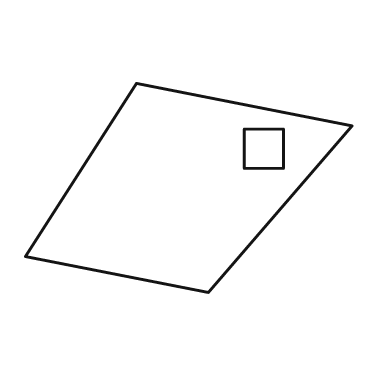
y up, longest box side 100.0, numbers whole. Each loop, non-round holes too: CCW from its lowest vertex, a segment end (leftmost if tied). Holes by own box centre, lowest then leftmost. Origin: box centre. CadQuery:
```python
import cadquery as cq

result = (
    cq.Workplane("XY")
    .moveTo(6.0, -32.0)
    .lineTo(50.0, 19.0)
    .lineTo(-16.0, 32.0)
    .lineTo(-50.0, -21.0)
    .close()
    .moveTo(17.0, 6.0)
    .lineTo(29.0, 6.0)
    .lineTo(29.0, 18.0)
    .lineTo(17.0, 18.0)
    .close()
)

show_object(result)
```